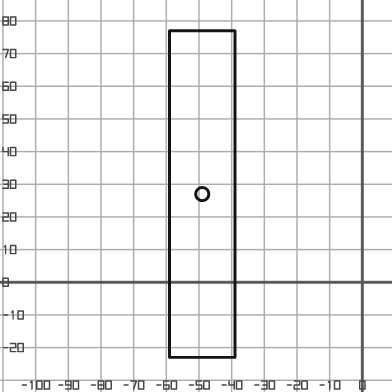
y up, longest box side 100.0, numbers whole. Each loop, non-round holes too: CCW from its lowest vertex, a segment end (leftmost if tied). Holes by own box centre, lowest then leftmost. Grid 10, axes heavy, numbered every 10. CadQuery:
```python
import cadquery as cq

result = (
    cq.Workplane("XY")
    .moveTo(-59.0, -23.0)
    .lineTo(-39.0, -23.0)
    .lineTo(-39.0, 77.0)
    .lineTo(-59.0, 77.0)
    .close()
    .moveTo(-49.0, 27.0)
    .circle(2.0)
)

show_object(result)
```